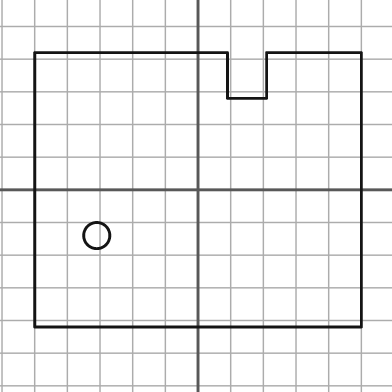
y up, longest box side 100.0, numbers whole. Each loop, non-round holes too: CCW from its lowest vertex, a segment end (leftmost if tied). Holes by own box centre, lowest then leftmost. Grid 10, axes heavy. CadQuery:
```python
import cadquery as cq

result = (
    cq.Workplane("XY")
    .moveTo(-50.0, -42.0)
    .lineTo(50.0, -42.0)
    .lineTo(50.0, 42.0)
    .lineTo(21.0, 42.0)
    .lineTo(21.0, 28.0)
    .lineTo(9.0, 28.0)
    .lineTo(9.0, 42.0)
    .lineTo(-50.0, 42.0)
    .close()
    .moveTo(-31.0, -14.0)
    .circle(4.0)
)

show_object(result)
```